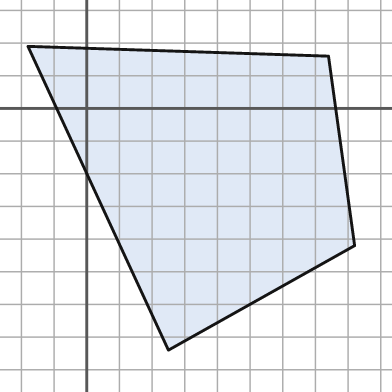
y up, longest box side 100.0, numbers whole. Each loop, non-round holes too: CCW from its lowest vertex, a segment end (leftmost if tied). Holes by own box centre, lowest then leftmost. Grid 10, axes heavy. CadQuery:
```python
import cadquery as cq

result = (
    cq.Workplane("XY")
    .moveTo(25.0, -74.0)
    .lineTo(82.0, -42.0)
    .lineTo(74.0, 16.0)
    .lineTo(-18.0, 19.0)
    .close()
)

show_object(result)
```